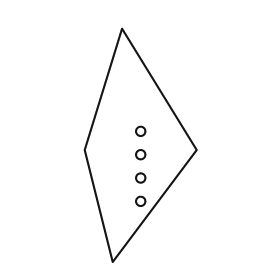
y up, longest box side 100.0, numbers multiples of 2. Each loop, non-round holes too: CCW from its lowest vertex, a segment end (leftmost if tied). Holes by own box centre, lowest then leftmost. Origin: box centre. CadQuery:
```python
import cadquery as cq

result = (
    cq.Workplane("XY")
    .moveTo(-12.0, -50.0)
    .lineTo(24.0, -2.0)
    .lineTo(-8.0, 50.0)
    .lineTo(-24.0, -2.0)
    .close()
    .moveTo(0.0, -24.0)
    .circle(2.0)
    .moveTo(0.0, -14.0)
    .circle(2.0)
    .moveTo(0.0, -4.0)
    .circle(2.0)
    .moveTo(0.0, 6.0)
    .circle(2.0)
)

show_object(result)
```